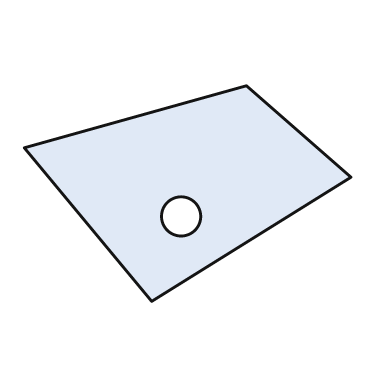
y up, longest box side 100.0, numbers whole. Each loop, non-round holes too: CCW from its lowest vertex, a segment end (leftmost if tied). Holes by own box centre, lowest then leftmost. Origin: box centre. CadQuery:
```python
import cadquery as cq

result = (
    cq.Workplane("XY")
    .moveTo(-11.0, -33.0)
    .lineTo(50.0, 5.0)
    .lineTo(18.0, 33.0)
    .lineTo(-50.0, 14.0)
    .close()
    .moveTo(-2.0, -7.0)
    .circle(6.0)
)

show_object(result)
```